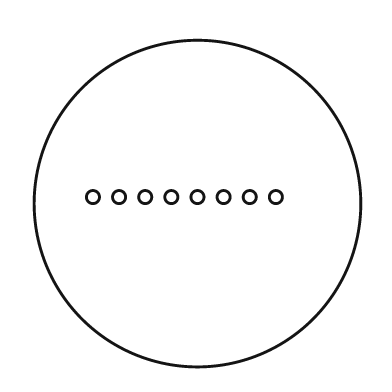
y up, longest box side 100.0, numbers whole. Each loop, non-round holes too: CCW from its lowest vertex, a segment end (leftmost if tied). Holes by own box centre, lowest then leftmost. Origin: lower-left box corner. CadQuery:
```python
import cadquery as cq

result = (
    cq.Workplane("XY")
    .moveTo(50.0, 50.0)
    .circle(50.0)
    .moveTo(18.0, 52.0)
    .circle(2.0)
    .moveTo(26.0, 52.0)
    .circle(2.0)
    .moveTo(34.0, 52.0)
    .circle(2.0)
    .moveTo(42.0, 52.0)
    .circle(2.0)
    .moveTo(50.0, 52.0)
    .circle(2.0)
    .moveTo(58.0, 52.0)
    .circle(2.0)
    .moveTo(66.0, 52.0)
    .circle(2.0)
    .moveTo(74.0, 52.0)
    .circle(2.0)
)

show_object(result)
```